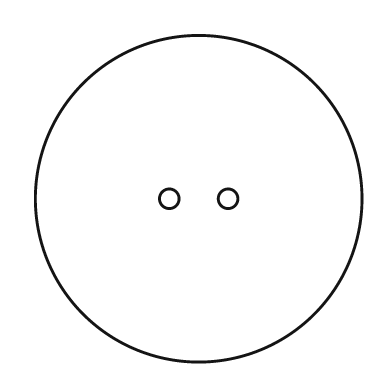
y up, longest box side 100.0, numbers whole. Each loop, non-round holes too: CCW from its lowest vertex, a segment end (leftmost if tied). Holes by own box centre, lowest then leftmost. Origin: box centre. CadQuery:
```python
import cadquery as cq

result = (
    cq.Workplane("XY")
    .moveTo(0.0, 0.0)
    .circle(50.0)
    .moveTo(-9.0, 0.0)
    .circle(3.0)
    .moveTo(9.0, 0.0)
    .circle(3.0)
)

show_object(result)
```